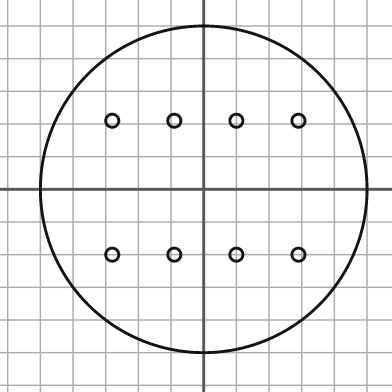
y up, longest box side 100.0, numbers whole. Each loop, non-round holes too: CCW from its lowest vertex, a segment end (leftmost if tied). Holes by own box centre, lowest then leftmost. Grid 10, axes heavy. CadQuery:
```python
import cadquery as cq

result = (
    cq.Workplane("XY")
    .moveTo(0.0, 0.0)
    .circle(50.0)
    .moveTo(-28.0, -20.0)
    .circle(2.0)
    .moveTo(-9.0, -20.0)
    .circle(2.0)
    .moveTo(10.0, -20.0)
    .circle(2.0)
    .moveTo(29.0, -20.0)
    .circle(2.0)
    .moveTo(-28.0, 21.0)
    .circle(2.0)
    .moveTo(-9.0, 21.0)
    .circle(2.0)
    .moveTo(10.0, 21.0)
    .circle(2.0)
    .moveTo(29.0, 21.0)
    .circle(2.0)
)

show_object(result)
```